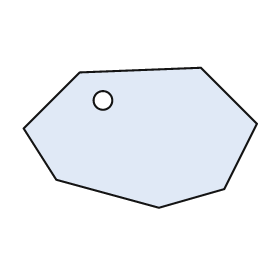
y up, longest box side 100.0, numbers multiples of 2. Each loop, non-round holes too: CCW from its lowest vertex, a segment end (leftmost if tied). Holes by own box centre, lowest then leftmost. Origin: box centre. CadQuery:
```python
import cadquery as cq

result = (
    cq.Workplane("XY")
    .moveTo(8.0, -30.0)
    .lineTo(36.0, -22.0)
    .lineTo(50.0, 6.0)
    .lineTo(26.0, 30.0)
    .lineTo(-26.0, 28.0)
    .lineTo(-50.0, 4.0)
    .lineTo(-36.0, -18.0)
    .close()
    .moveTo(-16.0, 16.0)
    .circle(4.0)
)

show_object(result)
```